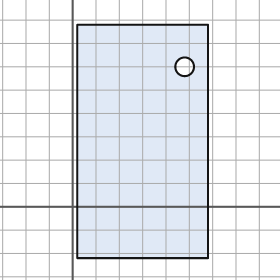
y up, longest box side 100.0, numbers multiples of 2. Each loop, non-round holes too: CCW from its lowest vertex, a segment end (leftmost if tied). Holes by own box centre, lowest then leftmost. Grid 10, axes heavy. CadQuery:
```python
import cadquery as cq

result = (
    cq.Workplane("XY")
    .moveTo(2.0, -22.0)
    .lineTo(58.0, -22.0)
    .lineTo(58.0, 78.0)
    .lineTo(2.0, 78.0)
    .close()
    .moveTo(48.0, 60.0)
    .circle(4.0)
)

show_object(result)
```